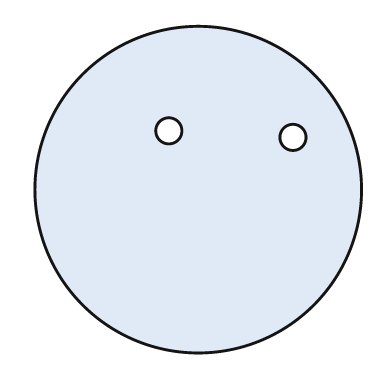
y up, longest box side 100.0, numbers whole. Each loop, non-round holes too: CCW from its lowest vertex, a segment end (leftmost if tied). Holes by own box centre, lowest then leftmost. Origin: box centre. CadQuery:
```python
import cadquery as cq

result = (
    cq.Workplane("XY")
    .moveTo(0.0, 0.0)
    .circle(50.0)
    .moveTo(29.0, 16.0)
    .circle(4.0)
    .moveTo(-9.0, 18.0)
    .circle(4.0)
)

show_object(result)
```